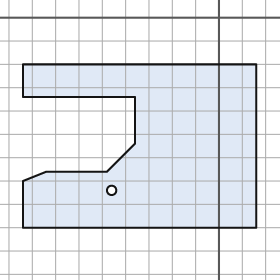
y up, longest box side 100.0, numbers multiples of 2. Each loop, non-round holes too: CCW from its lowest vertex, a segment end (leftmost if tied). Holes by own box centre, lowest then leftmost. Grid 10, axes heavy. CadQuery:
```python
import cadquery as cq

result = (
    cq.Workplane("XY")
    .moveTo(-84.0, -90.0)
    .lineTo(16.0, -90.0)
    .lineTo(16.0, -20.0)
    .lineTo(-84.0, -20.0)
    .lineTo(-84.0, -34.0)
    .lineTo(-36.0, -34.0)
    .lineTo(-36.0, -54.0)
    .lineTo(-48.0, -66.0)
    .lineTo(-74.0, -66.0)
    .lineTo(-84.0, -70.0)
    .close()
    .moveTo(-46.0, -74.0)
    .circle(2.0)
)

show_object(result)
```